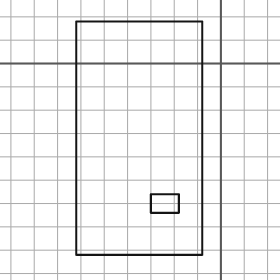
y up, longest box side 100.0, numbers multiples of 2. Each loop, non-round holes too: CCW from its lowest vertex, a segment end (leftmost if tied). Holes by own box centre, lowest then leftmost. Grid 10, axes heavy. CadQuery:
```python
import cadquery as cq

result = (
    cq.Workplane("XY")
    .moveTo(-62.0, -82.0)
    .lineTo(-8.0, -82.0)
    .lineTo(-8.0, 18.0)
    .lineTo(-62.0, 18.0)
    .close()
    .moveTo(-30.0, -64.0)
    .lineTo(-18.0, -64.0)
    .lineTo(-18.0, -56.0)
    .lineTo(-30.0, -56.0)
    .close()
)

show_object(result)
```